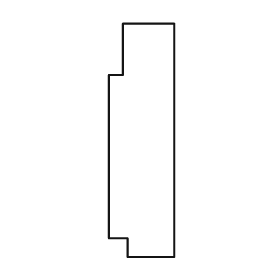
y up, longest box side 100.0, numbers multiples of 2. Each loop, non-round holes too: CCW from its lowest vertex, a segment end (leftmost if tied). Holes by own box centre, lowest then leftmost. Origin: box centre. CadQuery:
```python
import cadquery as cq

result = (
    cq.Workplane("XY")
    .moveTo(-6.0, -50.0)
    .lineTo(14.0, -50.0)
    .lineTo(14.0, 50.0)
    .lineTo(-8.0, 50.0)
    .lineTo(-8.0, 28.0)
    .lineTo(-14.0, 28.0)
    .lineTo(-14.0, -42.0)
    .lineTo(-6.0, -42.0)
    .close()
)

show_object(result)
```